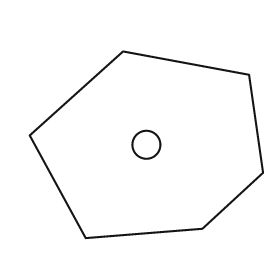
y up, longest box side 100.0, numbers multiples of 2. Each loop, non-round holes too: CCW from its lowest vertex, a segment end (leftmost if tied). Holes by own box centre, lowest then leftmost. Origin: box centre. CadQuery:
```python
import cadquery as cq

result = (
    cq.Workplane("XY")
    .moveTo(-26.0, -40.0)
    .lineTo(24.0, -36.0)
    .lineTo(50.0, -12.0)
    .lineTo(44.0, 30.0)
    .lineTo(-10.0, 40.0)
    .lineTo(-50.0, 4.0)
    .close()
    .moveTo(0.0, 0.0)
    .circle(6.0)
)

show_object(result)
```